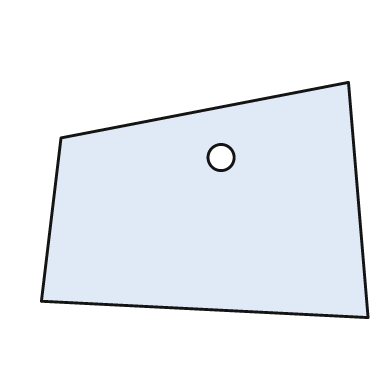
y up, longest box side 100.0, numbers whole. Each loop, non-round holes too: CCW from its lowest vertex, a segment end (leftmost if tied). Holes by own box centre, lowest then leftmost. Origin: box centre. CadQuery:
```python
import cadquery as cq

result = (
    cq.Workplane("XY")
    .moveTo(50.0, -36.0)
    .lineTo(44.0, 36.0)
    .lineTo(-44.0, 19.0)
    .lineTo(-50.0, -31.0)
    .close()
    .moveTo(5.0, 13.0)
    .circle(4.0)
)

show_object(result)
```